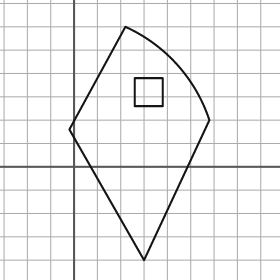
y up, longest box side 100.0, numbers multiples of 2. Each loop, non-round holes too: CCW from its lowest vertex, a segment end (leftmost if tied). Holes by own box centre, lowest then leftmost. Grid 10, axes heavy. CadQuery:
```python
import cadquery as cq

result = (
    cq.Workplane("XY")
    .moveTo(30.0, -40.0)
    .lineTo(58.0, 20.0)
    .threePointArc((44.0, 44.0), (22.0, 60.0))
    .lineTo(-2.0, 16.0)
    .close()
    .moveTo(26.0, 26.0)
    .lineTo(38.0, 26.0)
    .lineTo(38.0, 38.0)
    .lineTo(26.0, 38.0)
    .close()
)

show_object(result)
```